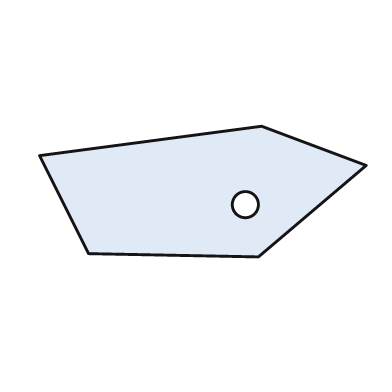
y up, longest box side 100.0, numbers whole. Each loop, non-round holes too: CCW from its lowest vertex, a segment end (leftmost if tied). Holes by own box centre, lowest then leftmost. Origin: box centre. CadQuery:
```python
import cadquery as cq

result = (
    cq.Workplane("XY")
    .moveTo(17.0, -20.0)
    .lineTo(50.0, 8.0)
    .lineTo(18.0, 20.0)
    .lineTo(-50.0, 11.0)
    .lineTo(-35.0, -19.0)
    .close()
    .moveTo(13.0, -4.0)
    .circle(4.0)
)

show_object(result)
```